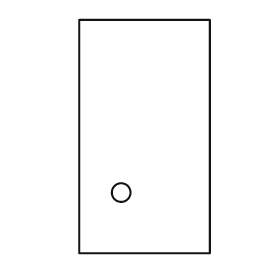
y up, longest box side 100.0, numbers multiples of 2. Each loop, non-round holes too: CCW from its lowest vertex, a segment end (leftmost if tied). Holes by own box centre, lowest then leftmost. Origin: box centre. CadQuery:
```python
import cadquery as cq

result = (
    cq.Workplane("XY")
    .moveTo(-28.0, -50.0)
    .lineTo(28.0, -50.0)
    .lineTo(28.0, 50.0)
    .lineTo(-28.0, 50.0)
    .close()
    .moveTo(-10.0, -24.0)
    .circle(4.0)
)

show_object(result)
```